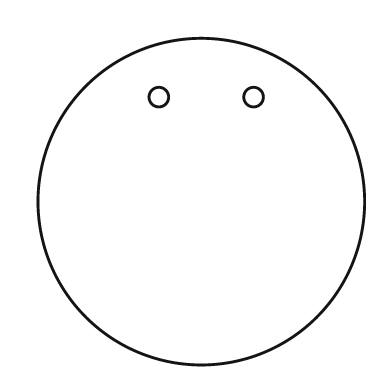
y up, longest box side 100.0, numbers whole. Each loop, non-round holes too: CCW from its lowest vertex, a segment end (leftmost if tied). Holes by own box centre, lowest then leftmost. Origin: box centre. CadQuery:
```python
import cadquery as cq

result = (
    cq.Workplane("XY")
    .moveTo(0.0, 0.0)
    .circle(50.0)
    .moveTo(-13.0, 32.0)
    .circle(3.0)
    .moveTo(16.0, 32.0)
    .circle(3.0)
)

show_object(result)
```